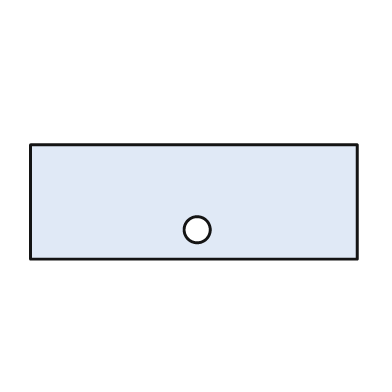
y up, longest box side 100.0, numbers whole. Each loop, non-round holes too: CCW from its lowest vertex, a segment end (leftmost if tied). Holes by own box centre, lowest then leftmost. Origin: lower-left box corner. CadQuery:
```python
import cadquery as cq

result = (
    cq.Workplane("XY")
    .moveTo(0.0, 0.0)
    .lineTo(100.0, 0.0)
    .lineTo(100.0, 35.0)
    .lineTo(0.0, 35.0)
    .close()
    .moveTo(51.0, 9.0)
    .circle(4.0)
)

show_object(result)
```